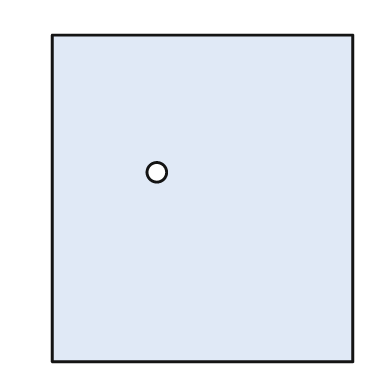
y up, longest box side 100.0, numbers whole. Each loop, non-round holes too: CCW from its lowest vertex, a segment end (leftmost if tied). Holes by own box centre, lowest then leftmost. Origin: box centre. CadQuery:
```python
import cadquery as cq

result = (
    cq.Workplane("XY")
    .moveTo(-46.0, -50.0)
    .lineTo(46.0, -50.0)
    .lineTo(46.0, 50.0)
    .lineTo(-46.0, 50.0)
    .close()
    .moveTo(-14.0, 8.0)
    .circle(3.0)
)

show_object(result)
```